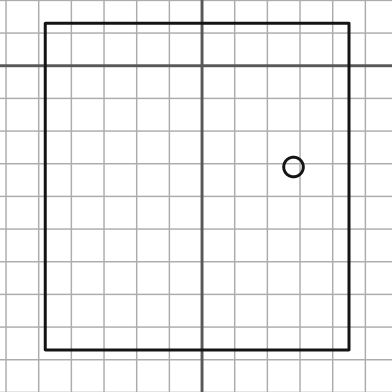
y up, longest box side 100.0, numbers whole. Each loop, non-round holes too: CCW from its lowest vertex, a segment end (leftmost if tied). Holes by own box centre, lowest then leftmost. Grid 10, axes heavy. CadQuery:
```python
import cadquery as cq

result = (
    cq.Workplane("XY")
    .moveTo(-48.0, -87.0)
    .lineTo(45.0, -87.0)
    .lineTo(45.0, 13.0)
    .lineTo(-48.0, 13.0)
    .close()
    .moveTo(28.0, -31.0)
    .circle(3.0)
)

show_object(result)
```